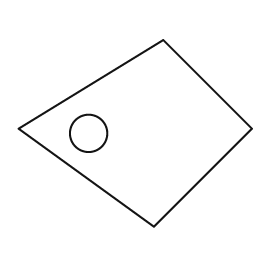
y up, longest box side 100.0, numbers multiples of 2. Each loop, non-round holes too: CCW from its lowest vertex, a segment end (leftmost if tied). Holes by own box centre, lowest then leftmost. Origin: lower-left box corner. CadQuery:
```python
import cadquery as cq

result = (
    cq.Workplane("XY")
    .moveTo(58.0, 0.0)
    .lineTo(100.0, 42.0)
    .lineTo(62.0, 80.0)
    .lineTo(0.0, 42.0)
    .close()
    .moveTo(30.0, 40.0)
    .circle(8.0)
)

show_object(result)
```